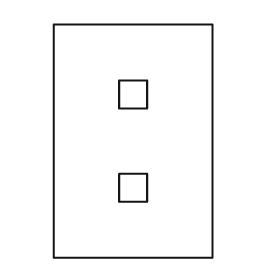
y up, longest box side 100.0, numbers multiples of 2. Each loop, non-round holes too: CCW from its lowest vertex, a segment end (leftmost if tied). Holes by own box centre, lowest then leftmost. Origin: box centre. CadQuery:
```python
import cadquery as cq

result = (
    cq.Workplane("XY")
    .moveTo(-34.0, -50.0)
    .lineTo(34.0, -50.0)
    .lineTo(34.0, 50.0)
    .lineTo(-34.0, 50.0)
    .close()
    .moveTo(-6.0, -26.0)
    .lineTo(6.0, -26.0)
    .lineTo(6.0, -14.0)
    .lineTo(-6.0, -14.0)
    .close()
    .moveTo(-6.0, 14.0)
    .lineTo(6.0, 14.0)
    .lineTo(6.0, 26.0)
    .lineTo(-6.0, 26.0)
    .close()
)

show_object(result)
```